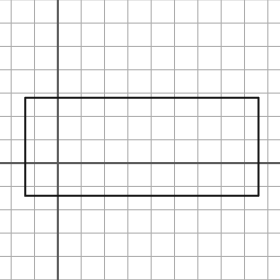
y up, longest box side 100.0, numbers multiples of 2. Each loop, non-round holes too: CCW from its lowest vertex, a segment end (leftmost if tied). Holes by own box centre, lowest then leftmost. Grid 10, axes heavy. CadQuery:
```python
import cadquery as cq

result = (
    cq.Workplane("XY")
    .moveTo(-14.0, -14.0)
    .lineTo(86.0, -14.0)
    .lineTo(86.0, 28.0)
    .lineTo(-14.0, 28.0)
    .close()
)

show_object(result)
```